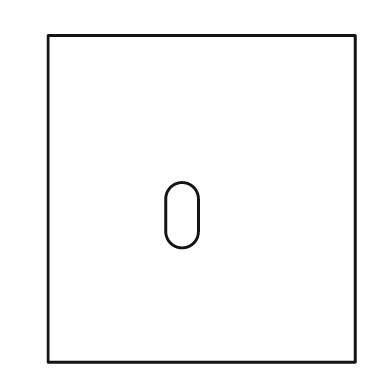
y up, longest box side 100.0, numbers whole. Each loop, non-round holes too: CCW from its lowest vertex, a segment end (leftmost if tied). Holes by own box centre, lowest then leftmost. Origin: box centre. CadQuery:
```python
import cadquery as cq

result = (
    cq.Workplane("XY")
    .moveTo(-47.0, -50.0)
    .lineTo(47.0, -50.0)
    .lineTo(47.0, 50.0)
    .lineTo(-47.0, 50.0)
    .close()
    .moveTo(-11.0, -10.0)
    .threePointArc((-6.0, -15.0), (-1.0, -10.0))
    .lineTo(-1.0, 0.0)
    .threePointArc((-6.0, 5.0), (-11.0, 0.0))
    .close()
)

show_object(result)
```